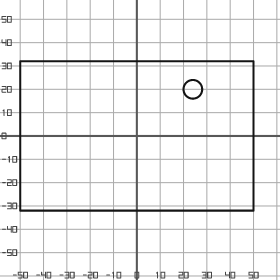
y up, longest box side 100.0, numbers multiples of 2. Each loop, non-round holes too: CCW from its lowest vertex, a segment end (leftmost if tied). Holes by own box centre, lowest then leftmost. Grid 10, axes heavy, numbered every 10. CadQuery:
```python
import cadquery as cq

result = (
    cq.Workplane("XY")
    .moveTo(-50.0, -32.0)
    .lineTo(50.0, -32.0)
    .lineTo(50.0, 32.0)
    .lineTo(-50.0, 32.0)
    .close()
    .moveTo(24.0, 20.0)
    .circle(4.0)
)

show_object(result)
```